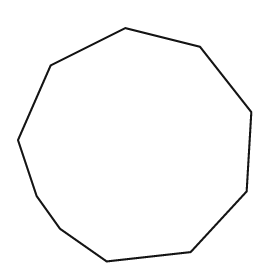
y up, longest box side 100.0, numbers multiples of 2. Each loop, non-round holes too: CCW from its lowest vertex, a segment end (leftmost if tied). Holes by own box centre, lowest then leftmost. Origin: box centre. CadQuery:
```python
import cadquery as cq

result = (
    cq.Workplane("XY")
    .moveTo(-12.0, -50.0)
    .lineTo(24.0, -46.0)
    .lineTo(48.0, -20.0)
    .lineTo(50.0, 14.0)
    .lineTo(28.0, 42.0)
    .lineTo(-4.0, 50.0)
    .lineTo(-36.0, 34.0)
    .lineTo(-50.0, 2.0)
    .lineTo(-42.0, -22.0)
    .lineTo(-32.0, -36.0)
    .close()
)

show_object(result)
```